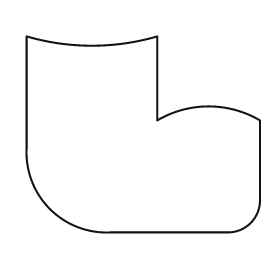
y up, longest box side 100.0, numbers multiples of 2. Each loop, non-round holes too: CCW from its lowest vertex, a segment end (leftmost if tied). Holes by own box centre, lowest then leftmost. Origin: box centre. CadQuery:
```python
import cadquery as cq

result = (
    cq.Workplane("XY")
    .moveTo(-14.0, -42.0)
    .lineTo(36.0, -42.0)
    .threePointArc((46.0, -38.0), (50.0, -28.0))
    .lineTo(50.0, 6.0)
    .threePointArc((28.0, 12.0), (6.0, 6.0))
    .lineTo(6.0, 42.0)
    .threePointArc((-22.0, 38.0), (-50.0, 42.0))
    .lineTo(-50.0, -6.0)
    .threePointArc((-40.0, -32.0), (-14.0, -42.0))
    .close()
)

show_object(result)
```